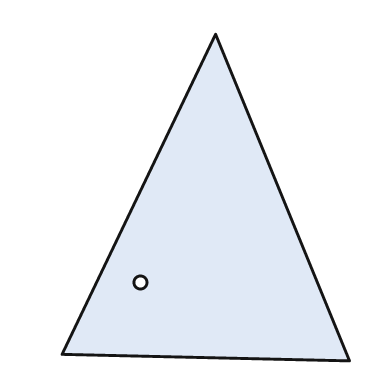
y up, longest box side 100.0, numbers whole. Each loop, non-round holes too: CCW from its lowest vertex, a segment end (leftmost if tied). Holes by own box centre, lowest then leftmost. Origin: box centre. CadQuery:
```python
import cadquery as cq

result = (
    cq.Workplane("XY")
    .moveTo(44.0, -50.0)
    .lineTo(3.0, 50.0)
    .lineTo(-44.0, -48.0)
    .close()
    .moveTo(-20.0, -26.0)
    .circle(2.0)
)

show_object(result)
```